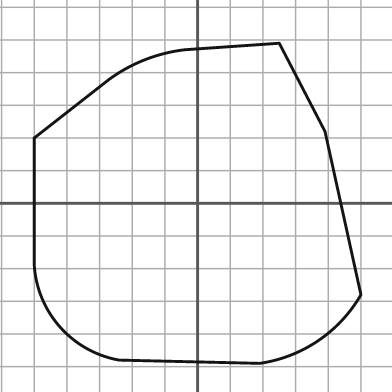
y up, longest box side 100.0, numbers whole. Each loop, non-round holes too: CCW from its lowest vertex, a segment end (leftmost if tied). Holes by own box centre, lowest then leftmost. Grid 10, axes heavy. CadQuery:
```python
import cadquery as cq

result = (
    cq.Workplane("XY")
    .moveTo(19.0, -49.0)
    .threePointArc((37.0, -42.0), (50.0, -28.0))
    .lineTo(39.0, 22.0)
    .lineTo(25.0, 49.0)
    .lineTo(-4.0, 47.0)
    .threePointArc((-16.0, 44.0), (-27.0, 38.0))
    .lineTo(-50.0, 20.0)
    .lineTo(-50.0, -19.0)
    .threePointArc((-42.0, -38.0), (-24.0, -48.0))
    .close()
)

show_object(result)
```